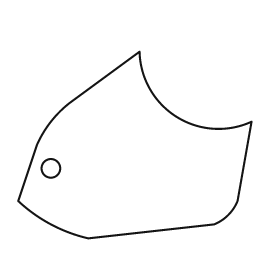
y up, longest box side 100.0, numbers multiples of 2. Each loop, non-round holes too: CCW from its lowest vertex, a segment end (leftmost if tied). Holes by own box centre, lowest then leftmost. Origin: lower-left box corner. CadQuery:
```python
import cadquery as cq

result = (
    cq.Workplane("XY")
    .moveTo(30.0, 0.0)
    .lineTo(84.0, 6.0)
    .threePointArc((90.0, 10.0), (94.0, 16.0))
    .lineTo(100.0, 50.0)
    .threePointArc((68.0, 52.0), (52.0, 80.0))
    .lineTo(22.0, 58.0)
    .threePointArc((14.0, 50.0), (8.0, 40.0))
    .lineTo(0.0, 16.0)
    .threePointArc((14.0, 6.0), (30.0, 0.0))
    .close()
    .moveTo(14.0, 30.0)
    .circle(4.0)
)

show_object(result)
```